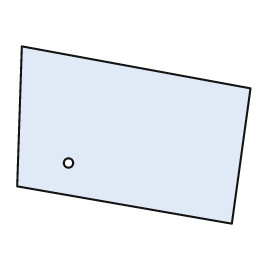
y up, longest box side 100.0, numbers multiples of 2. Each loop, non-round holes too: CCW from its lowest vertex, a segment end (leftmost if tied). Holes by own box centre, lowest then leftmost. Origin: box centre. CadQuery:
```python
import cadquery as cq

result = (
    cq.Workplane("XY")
    .moveTo(42.0, -38.0)
    .lineTo(50.0, 20.0)
    .lineTo(-48.0, 38.0)
    .lineTo(-50.0, -22.0)
    .close()
    .moveTo(-28.0, -12.0)
    .circle(2.0)
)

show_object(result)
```